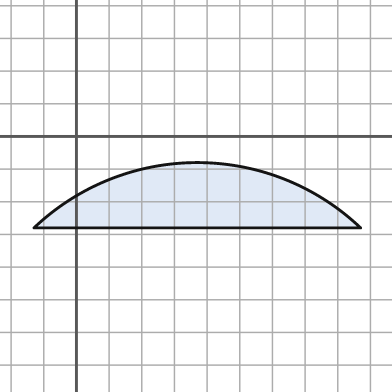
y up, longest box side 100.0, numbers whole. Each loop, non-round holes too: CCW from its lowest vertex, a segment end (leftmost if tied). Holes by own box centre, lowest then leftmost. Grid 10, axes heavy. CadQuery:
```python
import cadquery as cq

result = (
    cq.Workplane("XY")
    .moveTo(-13.0, -28.0)
    .lineTo(87.0, -28.0)
    .threePointArc((37.0, -8.0), (-13.0, -28.0))
    .close()
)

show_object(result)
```